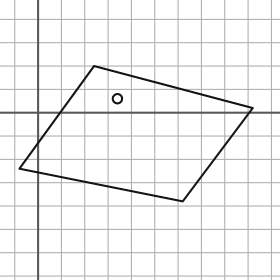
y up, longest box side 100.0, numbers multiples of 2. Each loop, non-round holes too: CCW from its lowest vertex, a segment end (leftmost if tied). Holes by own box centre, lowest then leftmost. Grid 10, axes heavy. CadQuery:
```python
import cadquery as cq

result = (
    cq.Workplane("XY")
    .moveTo(62.0, -38.0)
    .lineTo(92.0, 2.0)
    .lineTo(24.0, 20.0)
    .lineTo(-8.0, -24.0)
    .close()
    .moveTo(34.0, 6.0)
    .circle(2.0)
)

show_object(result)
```